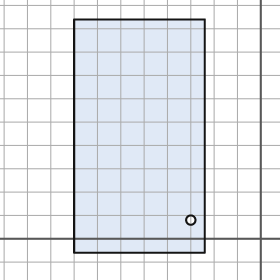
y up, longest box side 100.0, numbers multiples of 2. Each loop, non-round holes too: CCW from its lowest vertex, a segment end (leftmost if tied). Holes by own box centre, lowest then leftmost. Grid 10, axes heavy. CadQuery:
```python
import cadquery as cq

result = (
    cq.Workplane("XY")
    .moveTo(-80.0, -6.0)
    .lineTo(-24.0, -6.0)
    .lineTo(-24.0, 94.0)
    .lineTo(-80.0, 94.0)
    .close()
    .moveTo(-30.0, 8.0)
    .circle(2.0)
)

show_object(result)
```